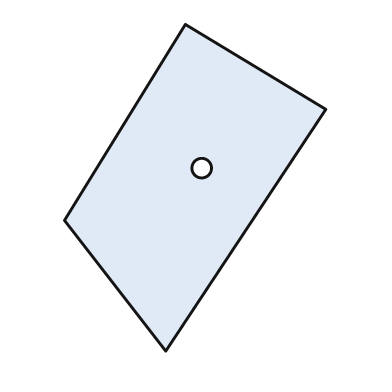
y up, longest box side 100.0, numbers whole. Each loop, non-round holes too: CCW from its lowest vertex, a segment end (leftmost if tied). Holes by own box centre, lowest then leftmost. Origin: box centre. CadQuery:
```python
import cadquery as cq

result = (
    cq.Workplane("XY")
    .moveTo(-9.0, -50.0)
    .lineTo(40.0, 24.0)
    .lineTo(-3.0, 50.0)
    .lineTo(-40.0, -10.0)
    .close()
    .moveTo(2.0, 6.0)
    .circle(3.0)
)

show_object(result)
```